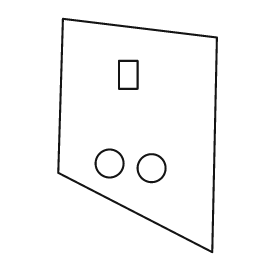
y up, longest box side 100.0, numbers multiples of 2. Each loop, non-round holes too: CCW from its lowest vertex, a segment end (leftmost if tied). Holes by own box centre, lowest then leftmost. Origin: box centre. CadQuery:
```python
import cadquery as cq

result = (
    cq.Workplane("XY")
    .moveTo(32.0, -50.0)
    .lineTo(34.0, 42.0)
    .lineTo(-32.0, 50.0)
    .lineTo(-34.0, -16.0)
    .close()
    .moveTo(6.0, -14.0)
    .circle(6.0)
    .moveTo(-12.0, -12.0)
    .circle(6.0)
    .moveTo(-8.0, 20.0)
    .lineTo(0.0, 20.0)
    .lineTo(0.0, 32.0)
    .lineTo(-8.0, 32.0)
    .close()
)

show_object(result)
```